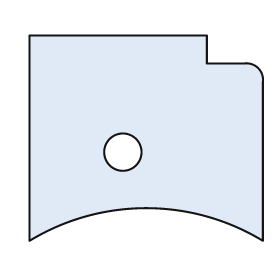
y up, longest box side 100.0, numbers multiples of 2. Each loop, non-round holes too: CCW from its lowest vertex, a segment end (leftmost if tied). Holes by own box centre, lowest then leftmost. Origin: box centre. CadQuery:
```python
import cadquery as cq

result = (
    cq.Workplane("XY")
    .moveTo(-50.0, -44.0)
    .threePointArc((0.0, -30.0), (50.0, -44.0))
    .lineTo(50.0, 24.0)
    .threePointArc((48.0, 30.0), (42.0, 32.0))
    .lineTo(26.0, 32.0)
    .lineTo(26.0, 44.0)
    .lineTo(-50.0, 44.0)
    .close()
    .moveTo(-10.0, -6.0)
    .circle(8.0)
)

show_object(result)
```